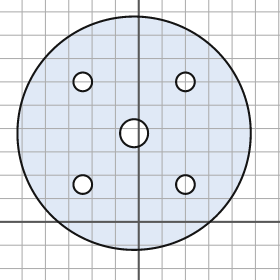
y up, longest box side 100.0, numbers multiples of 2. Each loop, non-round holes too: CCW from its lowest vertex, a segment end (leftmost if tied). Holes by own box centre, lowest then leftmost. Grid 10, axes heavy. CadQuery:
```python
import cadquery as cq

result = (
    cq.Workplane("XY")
    .moveTo(-2.0, 38.0)
    .circle(50.0)
    .moveTo(-24.0, 16.0)
    .circle(4.0)
    .moveTo(20.0, 16.0)
    .circle(4.0)
    .moveTo(-2.0, 38.0)
    .circle(6.0)
    .moveTo(-24.0, 60.0)
    .circle(4.0)
    .moveTo(20.0, 60.0)
    .circle(4.0)
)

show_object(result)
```